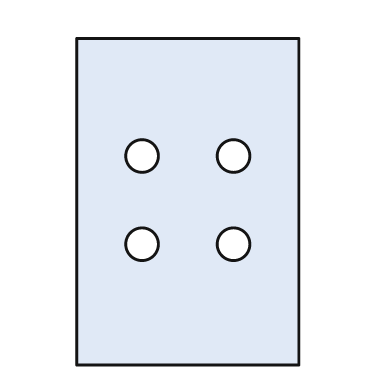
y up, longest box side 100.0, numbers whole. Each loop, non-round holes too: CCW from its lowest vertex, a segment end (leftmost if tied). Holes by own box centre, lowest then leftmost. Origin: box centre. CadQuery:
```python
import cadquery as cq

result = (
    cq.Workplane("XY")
    .moveTo(-34.0, -50.0)
    .lineTo(34.0, -50.0)
    .lineTo(34.0, 50.0)
    .lineTo(-34.0, 50.0)
    .close()
    .moveTo(-14.0, -13.0)
    .circle(5.0)
    .moveTo(14.0, -13.0)
    .circle(5.0)
    .moveTo(-14.0, 14.0)
    .circle(5.0)
    .moveTo(14.0, 14.0)
    .circle(5.0)
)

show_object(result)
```